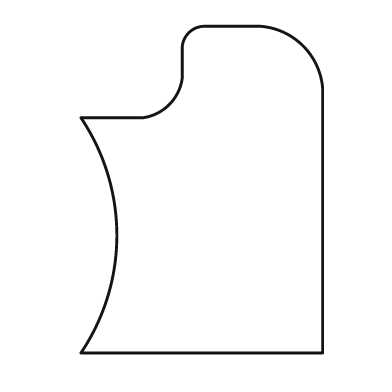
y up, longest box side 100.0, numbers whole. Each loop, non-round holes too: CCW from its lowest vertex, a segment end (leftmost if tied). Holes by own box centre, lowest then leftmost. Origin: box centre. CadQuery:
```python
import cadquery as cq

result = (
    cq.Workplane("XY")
    .moveTo(-37.0, -50.0)
    .lineTo(37.0, -50.0)
    .lineTo(37.0, 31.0)
    .threePointArc((31.0, 44.0), (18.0, 50.0))
    .lineTo(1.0, 50.0)
    .threePointArc((-4.0, 48.0), (-6.0, 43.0))
    .lineTo(-6.0, 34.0)
    .threePointArc((-10.0, 26.0), (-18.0, 22.0))
    .lineTo(-37.0, 22.0)
    .threePointArc((-26.0, -14.0), (-37.0, -50.0))
    .close()
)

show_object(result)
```